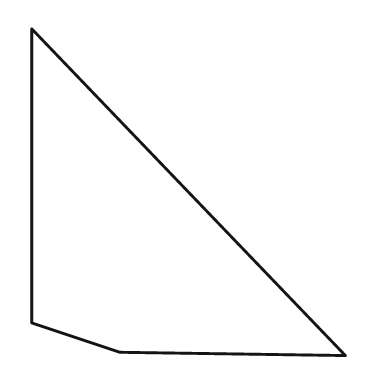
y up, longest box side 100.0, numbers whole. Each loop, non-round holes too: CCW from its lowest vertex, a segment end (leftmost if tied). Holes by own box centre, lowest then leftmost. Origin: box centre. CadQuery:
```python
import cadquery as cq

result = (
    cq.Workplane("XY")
    .moveTo(48.0, -50.0)
    .lineTo(-48.0, 50.0)
    .lineTo(-48.0, -40.0)
    .lineTo(-21.0, -49.0)
    .close()
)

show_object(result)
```